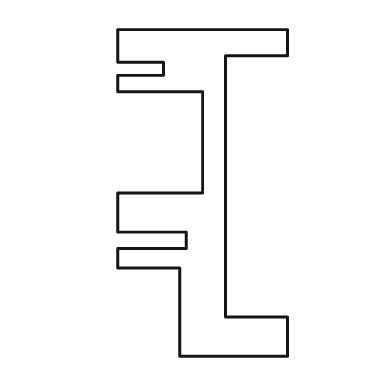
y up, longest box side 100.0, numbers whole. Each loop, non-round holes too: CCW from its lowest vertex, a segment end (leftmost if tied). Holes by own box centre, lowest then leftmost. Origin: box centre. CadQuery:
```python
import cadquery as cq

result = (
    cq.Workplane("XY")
    .moveTo(-7.0, -50.0)
    .lineTo(26.0, -50.0)
    .lineTo(26.0, -38.0)
    .lineTo(7.0, -38.0)
    .lineTo(7.0, 42.0)
    .lineTo(26.0, 42.0)
    .lineTo(26.0, 50.0)
    .lineTo(-26.0, 50.0)
    .lineTo(-26.0, 40.0)
    .lineTo(-12.0, 40.0)
    .lineTo(-12.0, 36.0)
    .lineTo(-26.0, 36.0)
    .lineTo(-26.0, 31.0)
    .lineTo(0.0, 31.0)
    .lineTo(0.0, 0.0)
    .lineTo(-26.0, 0.0)
    .lineTo(-26.0, -12.0)
    .lineTo(-5.0, -12.0)
    .lineTo(-5.0, -17.0)
    .lineTo(-26.0, -17.0)
    .lineTo(-26.0, -23.0)
    .lineTo(-7.0, -23.0)
    .close()
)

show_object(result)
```